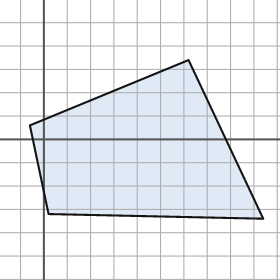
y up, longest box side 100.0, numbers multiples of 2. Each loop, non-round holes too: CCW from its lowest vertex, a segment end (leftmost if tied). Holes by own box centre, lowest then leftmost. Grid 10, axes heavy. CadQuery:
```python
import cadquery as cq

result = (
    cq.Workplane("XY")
    .moveTo(94.0, -34.0)
    .lineTo(62.0, 34.0)
    .lineTo(-6.0, 6.0)
    .lineTo(2.0, -32.0)
    .close()
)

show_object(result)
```